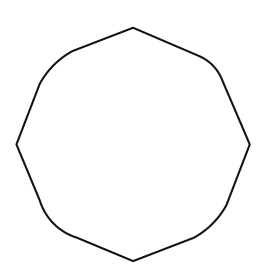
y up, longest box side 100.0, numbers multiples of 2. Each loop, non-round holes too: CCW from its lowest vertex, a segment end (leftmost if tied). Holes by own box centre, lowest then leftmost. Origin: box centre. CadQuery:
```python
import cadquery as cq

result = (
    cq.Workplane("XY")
    .moveTo(0.0, -50.0)
    .lineTo(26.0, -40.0)
    .threePointArc((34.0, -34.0), (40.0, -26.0))
    .lineTo(50.0, 0.0)
    .lineTo(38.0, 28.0)
    .threePointArc((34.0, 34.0), (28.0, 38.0))
    .lineTo(0.0, 50.0)
    .lineTo(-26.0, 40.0)
    .threePointArc((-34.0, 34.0), (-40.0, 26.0))
    .lineTo(-50.0, 0.0)
    .lineTo(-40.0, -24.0)
    .threePointArc((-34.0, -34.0), (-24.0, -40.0))
    .close()
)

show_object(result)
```